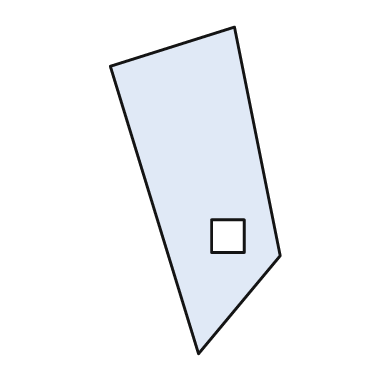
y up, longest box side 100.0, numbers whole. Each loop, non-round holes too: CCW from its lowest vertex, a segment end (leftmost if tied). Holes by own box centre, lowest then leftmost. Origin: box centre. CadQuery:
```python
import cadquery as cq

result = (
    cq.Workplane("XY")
    .moveTo(1.0, -50.0)
    .lineTo(26.0, -20.0)
    .lineTo(12.0, 50.0)
    .lineTo(-26.0, 38.0)
    .close()
    .moveTo(5.0, -19.0)
    .lineTo(15.0, -19.0)
    .lineTo(15.0, -9.0)
    .lineTo(5.0, -9.0)
    .close()
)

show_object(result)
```